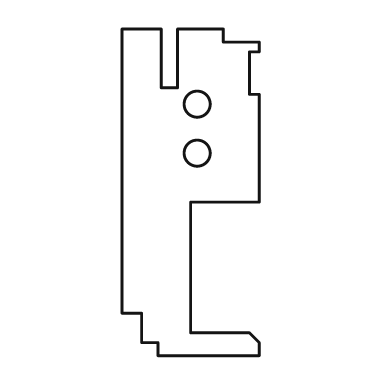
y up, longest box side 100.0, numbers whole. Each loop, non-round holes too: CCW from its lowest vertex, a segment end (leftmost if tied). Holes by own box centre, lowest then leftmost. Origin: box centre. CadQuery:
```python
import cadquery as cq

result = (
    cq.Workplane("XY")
    .moveTo(-10.0, -50.0)
    .lineTo(21.0, -50.0)
    .lineTo(21.0, -46.0)
    .lineTo(18.0, -43.0)
    .lineTo(0.0, -43.0)
    .lineTo(0.0, -3.0)
    .lineTo(21.0, -3.0)
    .lineTo(21.0, 30.0)
    .lineTo(18.0, 30.0)
    .lineTo(18.0, 43.0)
    .lineTo(21.0, 43.0)
    .lineTo(21.0, 46.0)
    .lineTo(10.0, 46.0)
    .lineTo(10.0, 50.0)
    .lineTo(-4.0, 50.0)
    .lineTo(-4.0, 32.0)
    .lineTo(-9.0, 32.0)
    .lineTo(-9.0, 50.0)
    .lineTo(-21.0, 50.0)
    .lineTo(-21.0, -37.0)
    .lineTo(-15.0, -37.0)
    .lineTo(-15.0, -46.0)
    .lineTo(-10.0, -46.0)
    .close()
    .moveTo(2.0, 12.0)
    .circle(4.0)
    .moveTo(2.0, 27.0)
    .circle(4.0)
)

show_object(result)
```